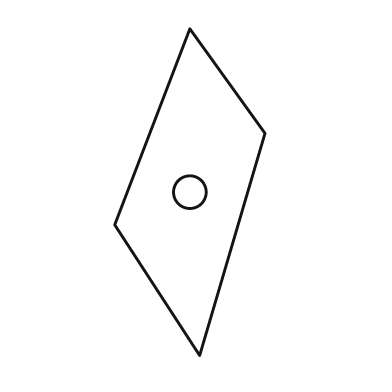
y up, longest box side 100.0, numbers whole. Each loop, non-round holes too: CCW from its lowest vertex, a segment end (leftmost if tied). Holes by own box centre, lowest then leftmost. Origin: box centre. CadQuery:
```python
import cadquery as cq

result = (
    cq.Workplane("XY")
    .moveTo(3.0, -50.0)
    .lineTo(23.0, 18.0)
    .lineTo(0.0, 50.0)
    .lineTo(-23.0, -10.0)
    .close()
    .moveTo(0.0, 0.0)
    .circle(5.0)
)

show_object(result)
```